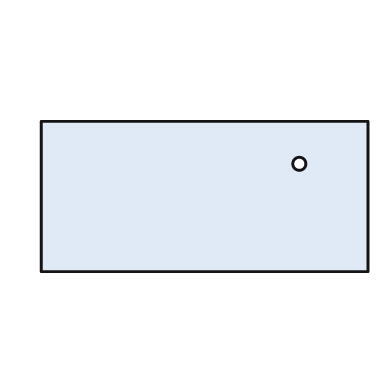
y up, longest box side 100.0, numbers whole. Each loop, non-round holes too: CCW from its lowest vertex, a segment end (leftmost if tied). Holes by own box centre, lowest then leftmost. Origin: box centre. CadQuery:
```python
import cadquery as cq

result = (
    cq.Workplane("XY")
    .moveTo(-50.0, -23.0)
    .lineTo(50.0, -23.0)
    .lineTo(50.0, 23.0)
    .lineTo(-50.0, 23.0)
    .close()
    .moveTo(29.0, 10.0)
    .circle(2.0)
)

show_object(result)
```